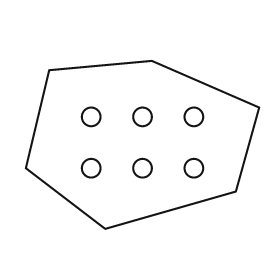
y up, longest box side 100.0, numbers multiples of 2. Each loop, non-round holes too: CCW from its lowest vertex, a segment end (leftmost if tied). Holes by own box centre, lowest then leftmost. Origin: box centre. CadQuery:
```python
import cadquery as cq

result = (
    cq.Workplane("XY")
    .moveTo(-16.0, -36.0)
    .lineTo(40.0, -20.0)
    .lineTo(50.0, 16.0)
    .lineTo(4.0, 36.0)
    .lineTo(-40.0, 32.0)
    .lineTo(-50.0, -10.0)
    .close()
    .moveTo(-22.0, -10.0)
    .circle(4.0)
    .moveTo(0.0, -10.0)
    .circle(4.0)
    .moveTo(22.0, -10.0)
    .circle(4.0)
    .moveTo(-22.0, 12.0)
    .circle(4.0)
    .moveTo(0.0, 12.0)
    .circle(4.0)
    .moveTo(22.0, 12.0)
    .circle(4.0)
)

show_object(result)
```